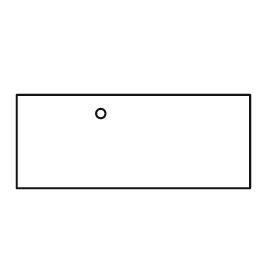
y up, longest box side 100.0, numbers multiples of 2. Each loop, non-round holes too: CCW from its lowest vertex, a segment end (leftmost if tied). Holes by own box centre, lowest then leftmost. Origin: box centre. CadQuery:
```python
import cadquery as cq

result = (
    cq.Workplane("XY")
    .moveTo(-50.0, -20.0)
    .lineTo(50.0, -20.0)
    .lineTo(50.0, 20.0)
    .lineTo(-50.0, 20.0)
    .close()
    .moveTo(-14.0, 12.0)
    .circle(2.0)
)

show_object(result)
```